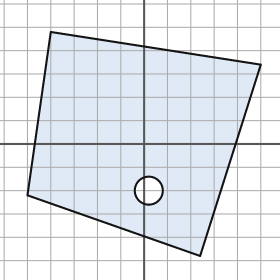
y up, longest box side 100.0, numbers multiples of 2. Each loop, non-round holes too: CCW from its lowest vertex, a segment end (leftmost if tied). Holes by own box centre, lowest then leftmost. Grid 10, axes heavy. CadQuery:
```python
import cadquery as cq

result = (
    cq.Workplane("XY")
    .moveTo(24.0, -48.0)
    .lineTo(50.0, 34.0)
    .lineTo(-40.0, 48.0)
    .lineTo(-50.0, -22.0)
    .close()
    .moveTo(2.0, -20.0)
    .circle(6.0)
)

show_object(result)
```